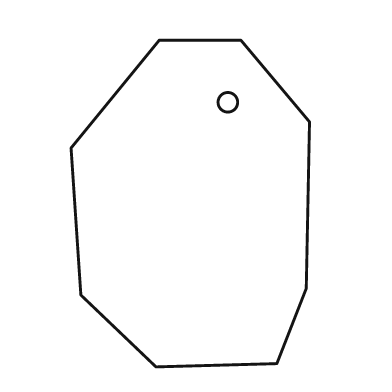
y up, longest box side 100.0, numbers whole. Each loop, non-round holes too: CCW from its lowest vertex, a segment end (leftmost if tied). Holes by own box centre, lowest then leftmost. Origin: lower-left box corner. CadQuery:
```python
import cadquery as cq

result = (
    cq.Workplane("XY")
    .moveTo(26.0, 0.0)
    .lineTo(63.0, 1.0)
    .lineTo(72.0, 24.0)
    .lineTo(73.0, 75.0)
    .lineTo(52.0, 100.0)
    .lineTo(27.0, 100.0)
    .lineTo(0.0, 67.0)
    .lineTo(3.0, 22.0)
    .close()
    .moveTo(48.0, 81.0)
    .circle(3.0)
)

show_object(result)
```